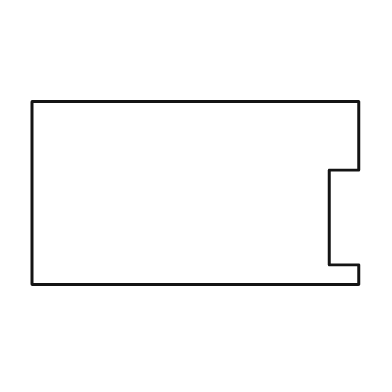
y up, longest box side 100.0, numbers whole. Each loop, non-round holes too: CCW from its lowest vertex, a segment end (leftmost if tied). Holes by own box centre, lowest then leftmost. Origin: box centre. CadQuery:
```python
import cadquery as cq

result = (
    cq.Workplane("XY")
    .moveTo(-50.0, -28.0)
    .lineTo(50.0, -28.0)
    .lineTo(50.0, -22.0)
    .lineTo(41.0, -22.0)
    .lineTo(41.0, 7.0)
    .lineTo(50.0, 7.0)
    .lineTo(50.0, 28.0)
    .lineTo(-50.0, 28.0)
    .close()
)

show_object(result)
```